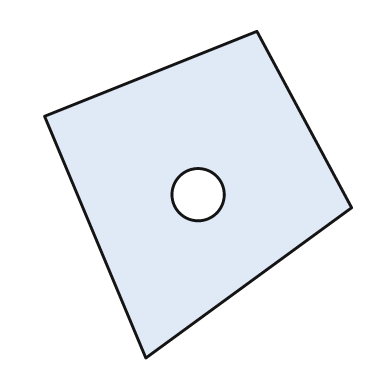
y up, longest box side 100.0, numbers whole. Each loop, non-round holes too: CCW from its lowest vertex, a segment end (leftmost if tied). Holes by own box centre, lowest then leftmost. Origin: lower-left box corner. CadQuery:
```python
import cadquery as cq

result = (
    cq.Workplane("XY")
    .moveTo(31.0, 0.0)
    .lineTo(94.0, 46.0)
    .lineTo(65.0, 100.0)
    .lineTo(0.0, 74.0)
    .close()
    .moveTo(47.0, 50.0)
    .circle(8.0)
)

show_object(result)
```